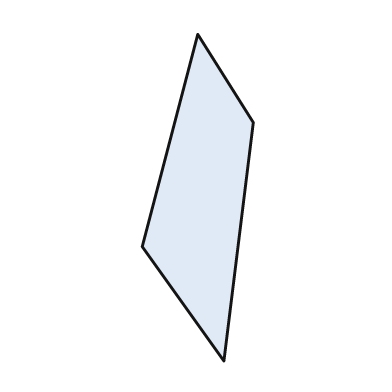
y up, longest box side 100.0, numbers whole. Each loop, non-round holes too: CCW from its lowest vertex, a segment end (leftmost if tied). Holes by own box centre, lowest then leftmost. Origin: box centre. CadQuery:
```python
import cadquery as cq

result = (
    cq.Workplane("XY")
    .moveTo(8.0, -50.0)
    .lineTo(17.0, 23.0)
    .lineTo(0.0, 50.0)
    .lineTo(-17.0, -15.0)
    .close()
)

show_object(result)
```